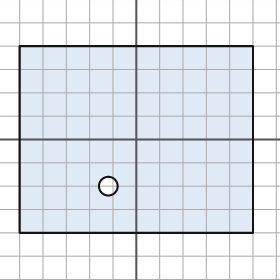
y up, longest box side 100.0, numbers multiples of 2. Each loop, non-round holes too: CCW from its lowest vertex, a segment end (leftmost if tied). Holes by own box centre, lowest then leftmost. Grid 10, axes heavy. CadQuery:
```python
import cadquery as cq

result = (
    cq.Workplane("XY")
    .moveTo(-50.0, -40.0)
    .lineTo(50.0, -40.0)
    .lineTo(50.0, 40.0)
    .lineTo(-50.0, 40.0)
    .close()
    .moveTo(-12.0, -20.0)
    .circle(4.0)
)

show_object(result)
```